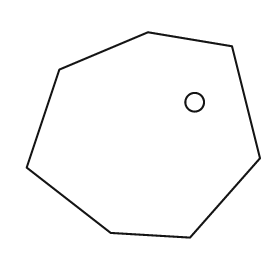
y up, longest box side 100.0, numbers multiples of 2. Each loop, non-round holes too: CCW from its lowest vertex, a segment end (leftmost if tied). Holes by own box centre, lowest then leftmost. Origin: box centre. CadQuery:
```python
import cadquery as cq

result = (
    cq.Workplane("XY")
    .moveTo(20.0, -44.0)
    .lineTo(50.0, -10.0)
    .lineTo(38.0, 38.0)
    .lineTo(2.0, 44.0)
    .lineTo(-36.0, 28.0)
    .lineTo(-50.0, -14.0)
    .lineTo(-14.0, -42.0)
    .close()
    .moveTo(22.0, 14.0)
    .circle(4.0)
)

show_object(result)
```